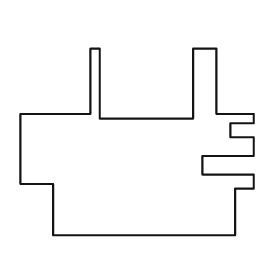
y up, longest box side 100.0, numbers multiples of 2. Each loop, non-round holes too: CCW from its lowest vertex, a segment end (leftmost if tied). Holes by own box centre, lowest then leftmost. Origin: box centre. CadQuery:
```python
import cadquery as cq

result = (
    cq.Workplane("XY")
    .moveTo(-36.0, -40.0)
    .lineTo(42.0, -40.0)
    .lineTo(42.0, -20.0)
    .lineTo(50.0, -20.0)
    .lineTo(50.0, -14.0)
    .lineTo(28.0, -14.0)
    .lineTo(28.0, -6.0)
    .lineTo(50.0, -6.0)
    .lineTo(50.0, 2.0)
    .lineTo(40.0, 2.0)
    .lineTo(40.0, 8.0)
    .lineTo(50.0, 8.0)
    .lineTo(50.0, 12.0)
    .lineTo(34.0, 12.0)
    .lineTo(34.0, 40.0)
    .lineTo(24.0, 40.0)
    .lineTo(24.0, 10.0)
    .lineTo(-16.0, 10.0)
    .lineTo(-16.0, 40.0)
    .lineTo(-20.0, 40.0)
    .lineTo(-20.0, 12.0)
    .lineTo(-50.0, 12.0)
    .lineTo(-50.0, -18.0)
    .lineTo(-36.0, -18.0)
    .close()
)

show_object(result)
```